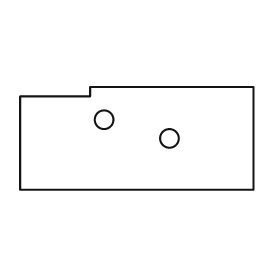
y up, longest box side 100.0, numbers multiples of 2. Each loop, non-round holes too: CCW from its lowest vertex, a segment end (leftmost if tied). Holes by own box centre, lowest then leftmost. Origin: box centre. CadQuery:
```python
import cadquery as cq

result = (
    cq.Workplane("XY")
    .moveTo(-50.0, -22.0)
    .lineTo(50.0, -22.0)
    .lineTo(50.0, 22.0)
    .lineTo(-20.0, 22.0)
    .lineTo(-20.0, 18.0)
    .lineTo(-50.0, 18.0)
    .close()
    .moveTo(14.0, 0.0)
    .circle(4.0)
    .moveTo(-14.0, 8.0)
    .circle(4.0)
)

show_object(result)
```